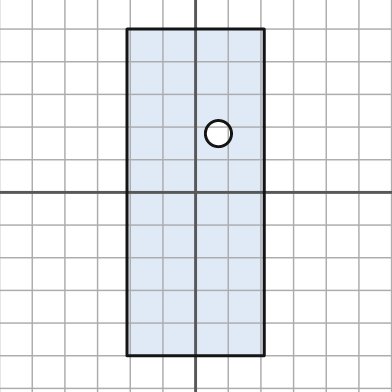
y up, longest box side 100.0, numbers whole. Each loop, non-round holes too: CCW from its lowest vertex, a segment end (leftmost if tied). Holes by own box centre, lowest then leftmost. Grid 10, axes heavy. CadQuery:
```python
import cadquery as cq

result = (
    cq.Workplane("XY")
    .moveTo(-21.0, -50.0)
    .lineTo(21.0, -50.0)
    .lineTo(21.0, 50.0)
    .lineTo(-21.0, 50.0)
    .close()
    .moveTo(7.0, 18.0)
    .circle(4.0)
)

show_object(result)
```